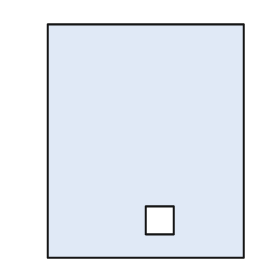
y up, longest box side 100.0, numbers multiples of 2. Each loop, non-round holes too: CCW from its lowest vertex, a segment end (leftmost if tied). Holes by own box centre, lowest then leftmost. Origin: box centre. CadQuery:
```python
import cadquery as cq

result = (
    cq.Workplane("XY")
    .moveTo(-42.0, -50.0)
    .lineTo(42.0, -50.0)
    .lineTo(42.0, 50.0)
    .lineTo(-42.0, 50.0)
    .close()
    .moveTo(0.0, -40.0)
    .lineTo(12.0, -40.0)
    .lineTo(12.0, -28.0)
    .lineTo(0.0, -28.0)
    .close()
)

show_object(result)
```